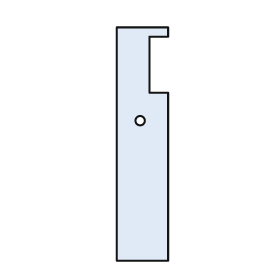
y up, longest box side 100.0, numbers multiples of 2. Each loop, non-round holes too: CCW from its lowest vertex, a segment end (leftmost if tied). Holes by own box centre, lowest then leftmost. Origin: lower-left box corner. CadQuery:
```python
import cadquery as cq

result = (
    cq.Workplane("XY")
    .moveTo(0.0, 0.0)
    .lineTo(22.0, 0.0)
    .lineTo(22.0, 72.0)
    .lineTo(14.0, 72.0)
    .lineTo(14.0, 96.0)
    .lineTo(22.0, 96.0)
    .lineTo(22.0, 100.0)
    .lineTo(0.0, 100.0)
    .close()
    .moveTo(10.0, 60.0)
    .circle(2.0)
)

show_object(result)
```